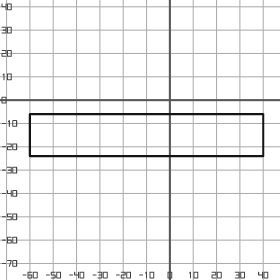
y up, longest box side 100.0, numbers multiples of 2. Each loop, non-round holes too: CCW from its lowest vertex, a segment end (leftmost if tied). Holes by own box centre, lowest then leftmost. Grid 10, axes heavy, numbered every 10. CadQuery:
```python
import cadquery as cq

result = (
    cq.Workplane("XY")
    .moveTo(-60.0, -24.0)
    .lineTo(40.0, -24.0)
    .lineTo(40.0, -6.0)
    .lineTo(-60.0, -6.0)
    .close()
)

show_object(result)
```